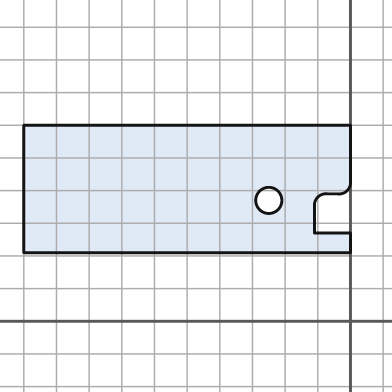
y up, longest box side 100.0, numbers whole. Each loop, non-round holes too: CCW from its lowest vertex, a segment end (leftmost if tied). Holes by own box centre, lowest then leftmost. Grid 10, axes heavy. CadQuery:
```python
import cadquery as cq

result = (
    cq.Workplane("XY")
    .moveTo(-100.0, 21.0)
    .lineTo(0.0, 21.0)
    .lineTo(0.0, 27.0)
    .lineTo(-11.0, 27.0)
    .lineTo(-11.0, 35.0)
    .threePointArc((-10.0, 38.0), (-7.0, 39.0))
    .lineTo(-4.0, 39.0)
    .threePointArc((-1.0, 40.0), (0.0, 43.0))
    .lineTo(0.0, 60.0)
    .lineTo(-100.0, 60.0)
    .close()
    .moveTo(-25.0, 37.0)
    .circle(4.0)
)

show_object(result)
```